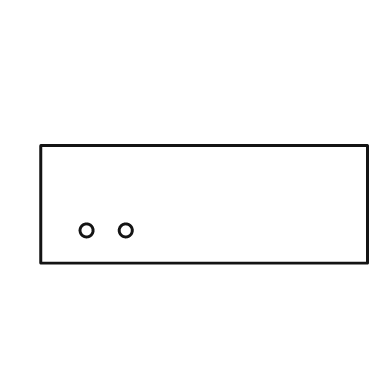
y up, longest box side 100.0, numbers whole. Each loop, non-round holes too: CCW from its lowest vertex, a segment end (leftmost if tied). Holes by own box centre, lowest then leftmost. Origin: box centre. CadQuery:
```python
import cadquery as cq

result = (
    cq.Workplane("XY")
    .moveTo(-50.0, -18.0)
    .lineTo(50.0, -18.0)
    .lineTo(50.0, 18.0)
    .lineTo(-50.0, 18.0)
    .close()
    .moveTo(-36.0, -8.0)
    .circle(2.0)
    .moveTo(-24.0, -8.0)
    .circle(2.0)
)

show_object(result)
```